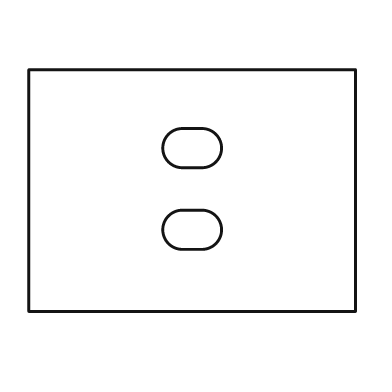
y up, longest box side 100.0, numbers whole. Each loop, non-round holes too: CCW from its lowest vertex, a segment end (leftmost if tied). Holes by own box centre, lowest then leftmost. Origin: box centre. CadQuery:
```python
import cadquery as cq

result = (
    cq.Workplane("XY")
    .moveTo(-50.0, -37.0)
    .lineTo(50.0, -37.0)
    .lineTo(50.0, 37.0)
    .lineTo(-50.0, 37.0)
    .close()
    .moveTo(-3.0, -18.0)
    .lineTo(3.0, -18.0)
    .threePointArc((9.0, -12.0), (3.0, -6.0))
    .lineTo(-3.0, -6.0)
    .threePointArc((-9.0, -12.0), (-3.0, -18.0))
    .close()
    .moveTo(-3.0, 7.0)
    .lineTo(3.0, 7.0)
    .threePointArc((9.0, 13.0), (3.0, 19.0))
    .lineTo(-3.0, 19.0)
    .threePointArc((-9.0, 13.0), (-3.0, 7.0))
    .close()
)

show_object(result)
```